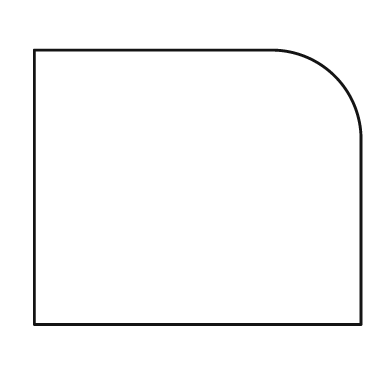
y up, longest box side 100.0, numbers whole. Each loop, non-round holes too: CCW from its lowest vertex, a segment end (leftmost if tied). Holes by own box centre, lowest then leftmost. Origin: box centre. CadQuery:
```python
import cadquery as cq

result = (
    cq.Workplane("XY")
    .moveTo(-50.0, -42.0)
    .lineTo(50.0, -42.0)
    .lineTo(50.0, 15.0)
    .threePointArc((42.0, 34.0), (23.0, 42.0))
    .lineTo(-50.0, 42.0)
    .close()
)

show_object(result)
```